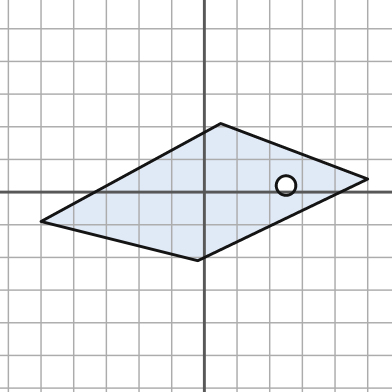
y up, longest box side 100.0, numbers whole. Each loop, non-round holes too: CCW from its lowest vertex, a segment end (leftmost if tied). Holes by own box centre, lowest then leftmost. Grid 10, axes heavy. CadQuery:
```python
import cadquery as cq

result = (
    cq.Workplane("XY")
    .moveTo(-2.0, -21.0)
    .lineTo(50.0, 4.0)
    .lineTo(5.0, 21.0)
    .lineTo(-50.0, -9.0)
    .close()
    .moveTo(25.0, 2.0)
    .circle(3.0)
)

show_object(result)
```